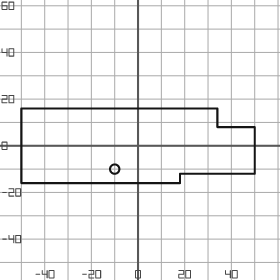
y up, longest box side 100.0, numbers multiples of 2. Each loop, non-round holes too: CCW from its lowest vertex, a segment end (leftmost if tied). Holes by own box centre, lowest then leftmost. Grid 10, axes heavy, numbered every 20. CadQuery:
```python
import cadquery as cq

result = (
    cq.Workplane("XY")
    .moveTo(-50.0, -16.0)
    .lineTo(18.0, -16.0)
    .lineTo(18.0, -12.0)
    .lineTo(50.0, -12.0)
    .lineTo(50.0, 8.0)
    .lineTo(34.0, 8.0)
    .lineTo(34.0, 16.0)
    .lineTo(-50.0, 16.0)
    .close()
    .moveTo(-10.0, -10.0)
    .circle(2.0)
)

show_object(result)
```